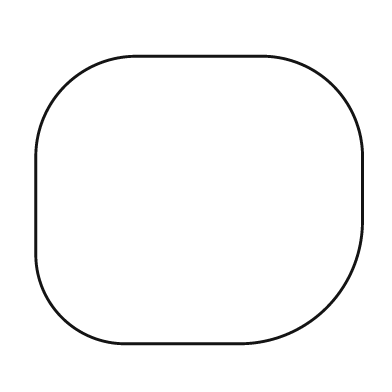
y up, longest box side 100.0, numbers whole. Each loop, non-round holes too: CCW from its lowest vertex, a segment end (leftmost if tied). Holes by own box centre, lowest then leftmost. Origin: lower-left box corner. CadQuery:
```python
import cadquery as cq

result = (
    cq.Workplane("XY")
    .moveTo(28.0, 0.0)
    .lineTo(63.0, 0.0)
    .threePointArc((89.0, 11.0), (100.0, 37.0))
    .lineTo(100.0, 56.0)
    .threePointArc((91.0, 79.0), (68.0, 88.0))
    .lineTo(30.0, 88.0)
    .threePointArc((9.0, 79.0), (0.0, 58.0))
    .lineTo(0.0, 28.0)
    .threePointArc((8.0, 8.0), (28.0, 0.0))
    .close()
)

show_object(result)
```